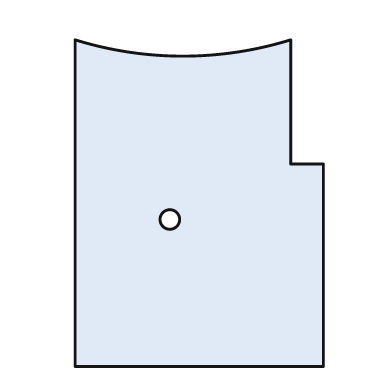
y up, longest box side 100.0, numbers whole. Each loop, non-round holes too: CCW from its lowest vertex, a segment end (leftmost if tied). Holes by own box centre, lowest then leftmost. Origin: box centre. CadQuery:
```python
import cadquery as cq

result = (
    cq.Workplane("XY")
    .moveTo(-38.0, -50.0)
    .lineTo(38.0, -50.0)
    .lineTo(38.0, 12.0)
    .lineTo(28.0, 12.0)
    .lineTo(28.0, 50.0)
    .threePointArc((-5.0, 45.0), (-38.0, 50.0))
    .close()
    .moveTo(-9.0, -5.0)
    .circle(3.0)
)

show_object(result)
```